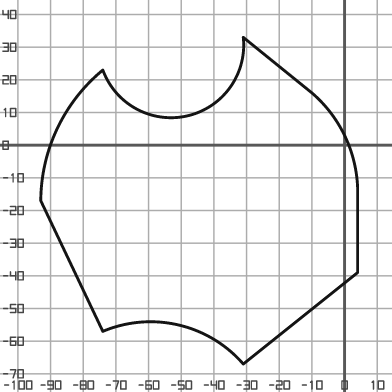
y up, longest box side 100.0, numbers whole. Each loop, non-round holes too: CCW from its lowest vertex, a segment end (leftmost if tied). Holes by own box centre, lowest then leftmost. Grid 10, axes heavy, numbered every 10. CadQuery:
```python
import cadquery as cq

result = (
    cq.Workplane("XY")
    .moveTo(-31.0, -67.0)
    .lineTo(4.0, -39.0)
    .lineTo(4.0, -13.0)
    .threePointArc((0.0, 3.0), (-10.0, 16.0))
    .lineTo(-31.0, 33.0)
    .threePointArc((-48.0, 9.0), (-74.0, 23.0))
    .threePointArc((-88.0, 5.0), (-93.0, -17.0))
    .lineTo(-74.0, -57.0)
    .threePointArc((-51.0, -55.0), (-31.0, -67.0))
    .close()
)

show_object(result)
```